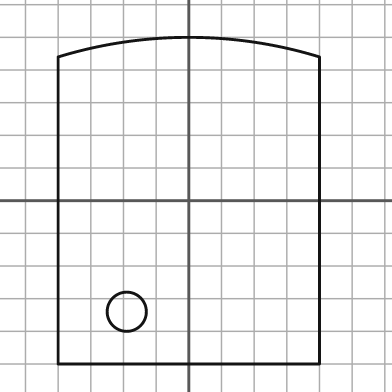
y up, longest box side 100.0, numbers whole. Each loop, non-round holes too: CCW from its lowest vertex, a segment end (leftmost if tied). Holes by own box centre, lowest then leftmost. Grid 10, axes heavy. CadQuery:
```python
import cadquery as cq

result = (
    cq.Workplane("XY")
    .moveTo(-40.0, -50.0)
    .lineTo(40.0, -50.0)
    .lineTo(40.0, 44.0)
    .threePointArc((0.0, 50.0), (-40.0, 44.0))
    .close()
    .moveTo(-19.0, -34.0)
    .circle(6.0)
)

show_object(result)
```